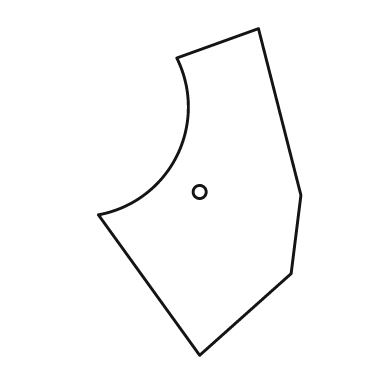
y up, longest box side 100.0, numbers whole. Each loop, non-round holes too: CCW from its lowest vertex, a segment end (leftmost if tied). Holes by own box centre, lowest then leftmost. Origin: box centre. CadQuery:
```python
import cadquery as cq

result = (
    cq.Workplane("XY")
    .moveTo(0.0, -50.0)
    .lineTo(28.0, -25.0)
    .lineTo(31.0, -1.0)
    .lineTo(18.0, 50.0)
    .lineTo(-7.0, 41.0)
    .threePointArc((-7.0, 11.0), (-31.0, -7.0))
    .close()
    .moveTo(0.0, 0.0)
    .circle(2.0)
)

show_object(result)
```